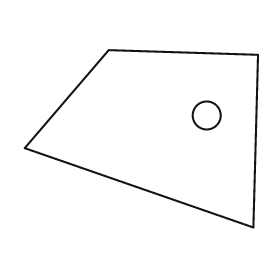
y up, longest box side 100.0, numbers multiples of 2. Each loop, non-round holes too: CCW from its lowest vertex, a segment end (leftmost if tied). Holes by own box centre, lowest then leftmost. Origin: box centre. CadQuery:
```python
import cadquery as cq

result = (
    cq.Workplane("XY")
    .moveTo(48.0, -38.0)
    .lineTo(50.0, 36.0)
    .lineTo(-14.0, 38.0)
    .lineTo(-50.0, -4.0)
    .close()
    .moveTo(28.0, 10.0)
    .circle(6.0)
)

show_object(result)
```